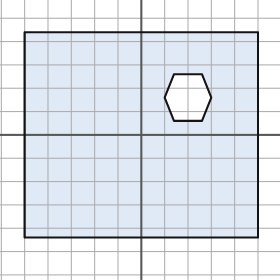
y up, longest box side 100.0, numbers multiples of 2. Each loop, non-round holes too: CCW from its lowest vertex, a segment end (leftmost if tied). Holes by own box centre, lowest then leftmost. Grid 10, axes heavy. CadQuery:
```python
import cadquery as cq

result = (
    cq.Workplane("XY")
    .moveTo(-50.0, -44.0)
    .lineTo(50.0, -44.0)
    .lineTo(50.0, 44.0)
    .lineTo(-50.0, 44.0)
    .close()
    .moveTo(14.0, 6.0)
    .lineTo(26.0, 6.0)
    .lineTo(30.0, 16.0)
    .lineTo(26.0, 26.0)
    .lineTo(14.0, 26.0)
    .lineTo(10.0, 16.0)
    .close()
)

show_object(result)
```